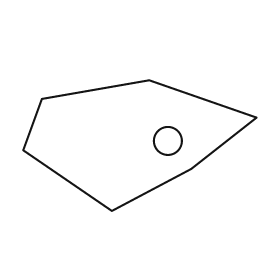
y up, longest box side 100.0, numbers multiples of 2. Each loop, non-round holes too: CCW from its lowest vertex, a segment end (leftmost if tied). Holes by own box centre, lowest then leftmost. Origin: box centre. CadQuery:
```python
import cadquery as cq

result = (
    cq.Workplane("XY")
    .moveTo(-12.0, -28.0)
    .lineTo(22.0, -10.0)
    .lineTo(50.0, 12.0)
    .lineTo(4.0, 28.0)
    .lineTo(-42.0, 20.0)
    .lineTo(-50.0, -2.0)
    .close()
    .moveTo(12.0, 2.0)
    .circle(6.0)
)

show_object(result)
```